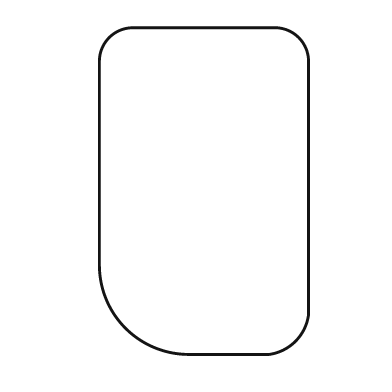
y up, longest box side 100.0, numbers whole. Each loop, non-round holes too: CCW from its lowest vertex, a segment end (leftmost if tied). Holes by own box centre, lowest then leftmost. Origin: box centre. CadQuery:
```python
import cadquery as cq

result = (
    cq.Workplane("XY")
    .moveTo(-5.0, -50.0)
    .lineTo(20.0, -50.0)
    .threePointArc((28.0, -46.0), (32.0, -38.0))
    .lineTo(32.0, 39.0)
    .threePointArc((29.0, 47.0), (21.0, 50.0))
    .lineTo(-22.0, 50.0)
    .threePointArc((-29.0, 47.0), (-32.0, 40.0))
    .lineTo(-32.0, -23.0)
    .threePointArc((-24.0, -42.0), (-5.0, -50.0))
    .close()
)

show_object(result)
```